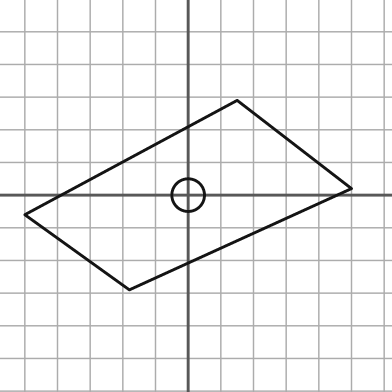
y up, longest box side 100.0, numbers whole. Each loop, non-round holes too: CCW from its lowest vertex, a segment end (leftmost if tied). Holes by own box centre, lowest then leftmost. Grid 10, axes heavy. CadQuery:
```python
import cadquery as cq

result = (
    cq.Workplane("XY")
    .moveTo(-18.0, -29.0)
    .lineTo(50.0, 2.0)
    .lineTo(15.0, 29.0)
    .lineTo(-50.0, -6.0)
    .close()
    .moveTo(0.0, 0.0)
    .circle(5.0)
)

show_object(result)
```